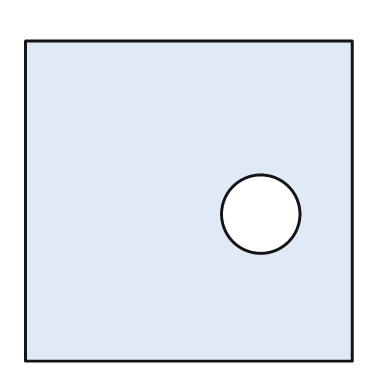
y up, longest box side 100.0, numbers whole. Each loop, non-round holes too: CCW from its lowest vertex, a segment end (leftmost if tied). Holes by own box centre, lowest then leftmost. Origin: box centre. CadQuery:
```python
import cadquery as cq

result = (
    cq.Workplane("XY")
    .moveTo(-50.0, -49.0)
    .lineTo(50.0, -49.0)
    .lineTo(50.0, 49.0)
    .lineTo(-50.0, 49.0)
    .close()
    .moveTo(22.0, -4.0)
    .circle(12.0)
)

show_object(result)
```